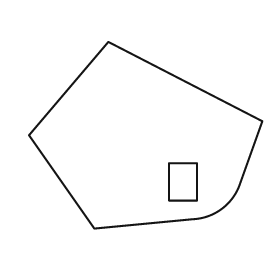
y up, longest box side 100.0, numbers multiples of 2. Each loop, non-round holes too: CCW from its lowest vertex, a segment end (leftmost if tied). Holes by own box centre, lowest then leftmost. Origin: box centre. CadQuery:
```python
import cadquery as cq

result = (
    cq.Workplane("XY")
    .moveTo(-22.0, -40.0)
    .lineTo(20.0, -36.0)
    .threePointArc((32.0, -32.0), (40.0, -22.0))
    .lineTo(50.0, 6.0)
    .lineTo(-16.0, 40.0)
    .lineTo(-50.0, 0.0)
    .close()
    .moveTo(10.0, -28.0)
    .lineTo(22.0, -28.0)
    .lineTo(22.0, -12.0)
    .lineTo(10.0, -12.0)
    .close()
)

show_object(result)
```